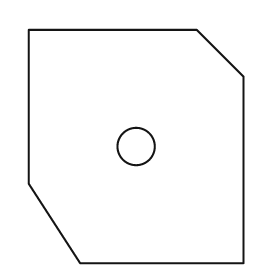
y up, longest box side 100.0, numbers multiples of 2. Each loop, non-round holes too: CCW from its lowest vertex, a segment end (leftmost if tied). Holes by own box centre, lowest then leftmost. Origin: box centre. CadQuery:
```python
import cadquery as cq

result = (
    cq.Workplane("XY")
    .moveTo(-24.0, -50.0)
    .lineTo(46.0, -50.0)
    .lineTo(46.0, 30.0)
    .lineTo(26.0, 50.0)
    .lineTo(-46.0, 50.0)
    .lineTo(-46.0, -16.0)
    .close()
    .moveTo(0.0, 0.0)
    .circle(8.0)
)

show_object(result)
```